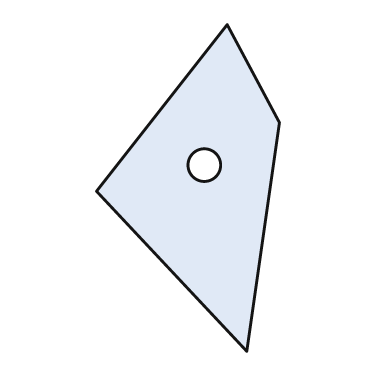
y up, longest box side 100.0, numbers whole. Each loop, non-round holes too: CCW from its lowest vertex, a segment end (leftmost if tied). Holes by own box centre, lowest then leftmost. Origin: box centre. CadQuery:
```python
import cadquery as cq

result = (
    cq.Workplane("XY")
    .moveTo(18.0, -50.0)
    .lineTo(28.0, 20.0)
    .lineTo(12.0, 50.0)
    .lineTo(-28.0, -1.0)
    .close()
    .moveTo(5.0, 7.0)
    .circle(5.0)
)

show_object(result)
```